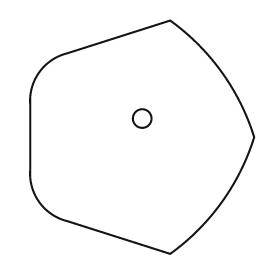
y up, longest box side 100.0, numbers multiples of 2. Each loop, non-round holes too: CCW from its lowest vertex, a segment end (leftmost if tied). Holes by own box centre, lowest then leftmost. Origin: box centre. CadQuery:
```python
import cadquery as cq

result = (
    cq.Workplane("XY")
    .moveTo(12.0, -50.0)
    .threePointArc((34.0, -28.0), (48.0, 0.0))
    .threePointArc((34.0, 28.0), (12.0, 50.0))
    .lineTo(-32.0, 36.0)
    .threePointArc((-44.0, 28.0), (-48.0, 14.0))
    .lineTo(-48.0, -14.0)
    .threePointArc((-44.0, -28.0), (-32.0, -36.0))
    .close()
    .moveTo(0.0, 8.0)
    .circle(4.0)
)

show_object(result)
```